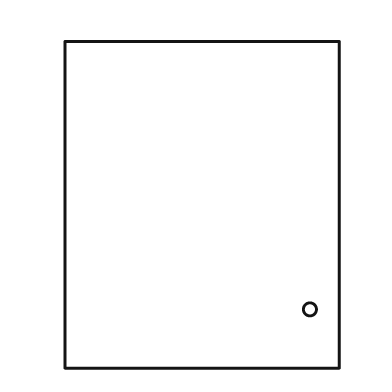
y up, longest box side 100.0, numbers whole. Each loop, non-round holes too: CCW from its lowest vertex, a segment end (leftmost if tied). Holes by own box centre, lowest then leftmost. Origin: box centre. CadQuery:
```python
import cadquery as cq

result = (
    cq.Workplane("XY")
    .moveTo(-42.0, -50.0)
    .lineTo(42.0, -50.0)
    .lineTo(42.0, 50.0)
    .lineTo(-42.0, 50.0)
    .close()
    .moveTo(33.0, -32.0)
    .circle(2.0)
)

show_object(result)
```